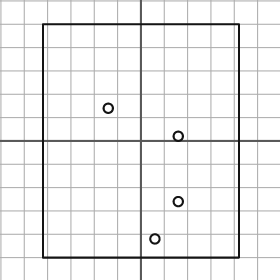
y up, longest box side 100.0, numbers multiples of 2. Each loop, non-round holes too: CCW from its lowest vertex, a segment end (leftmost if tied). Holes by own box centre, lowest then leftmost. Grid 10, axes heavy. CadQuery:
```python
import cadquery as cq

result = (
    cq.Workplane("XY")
    .moveTo(-42.0, -50.0)
    .lineTo(42.0, -50.0)
    .lineTo(42.0, 50.0)
    .lineTo(-42.0, 50.0)
    .close()
    .moveTo(6.0, -42.0)
    .circle(2.0)
    .moveTo(16.0, -26.0)
    .circle(2.0)
    .moveTo(16.0, 2.0)
    .circle(2.0)
    .moveTo(-14.0, 14.0)
    .circle(2.0)
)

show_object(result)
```